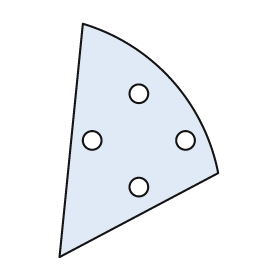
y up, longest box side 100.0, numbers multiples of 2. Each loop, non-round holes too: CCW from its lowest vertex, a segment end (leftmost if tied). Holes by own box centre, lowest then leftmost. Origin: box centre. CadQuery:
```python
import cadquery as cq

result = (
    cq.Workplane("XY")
    .moveTo(-34.0, -50.0)
    .lineTo(34.0, -14.0)
    .threePointArc((14.0, 26.0), (-24.0, 50.0))
    .close()
    .moveTo(0.0, -20.0)
    .circle(4.0)
    .moveTo(-20.0, 0.0)
    .circle(4.0)
    .moveTo(20.0, 0.0)
    .circle(4.0)
    .moveTo(0.0, 20.0)
    .circle(4.0)
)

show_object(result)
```